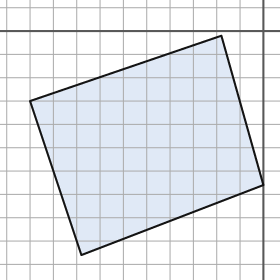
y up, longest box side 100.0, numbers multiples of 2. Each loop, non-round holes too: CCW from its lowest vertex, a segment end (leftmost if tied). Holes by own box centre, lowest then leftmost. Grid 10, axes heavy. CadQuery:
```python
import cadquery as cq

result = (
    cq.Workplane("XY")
    .moveTo(-78.0, -96.0)
    .lineTo(0.0, -66.0)
    .lineTo(-18.0, -2.0)
    .lineTo(-100.0, -30.0)
    .close()
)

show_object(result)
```